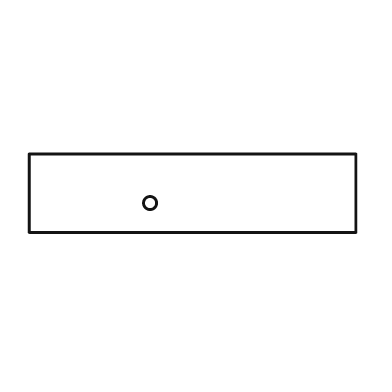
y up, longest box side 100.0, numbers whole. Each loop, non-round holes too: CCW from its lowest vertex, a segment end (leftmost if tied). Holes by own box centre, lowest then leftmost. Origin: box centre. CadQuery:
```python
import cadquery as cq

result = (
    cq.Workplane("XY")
    .moveTo(-50.0, -12.0)
    .lineTo(50.0, -12.0)
    .lineTo(50.0, 12.0)
    .lineTo(-50.0, 12.0)
    .close()
    .moveTo(-13.0, -3.0)
    .circle(2.0)
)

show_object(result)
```